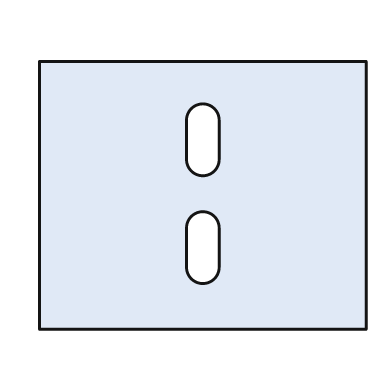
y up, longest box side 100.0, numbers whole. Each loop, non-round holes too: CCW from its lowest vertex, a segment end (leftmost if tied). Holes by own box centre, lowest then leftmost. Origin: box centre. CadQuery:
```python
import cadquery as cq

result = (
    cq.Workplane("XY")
    .moveTo(-50.0, -41.0)
    .lineTo(50.0, -41.0)
    .lineTo(50.0, 41.0)
    .lineTo(-50.0, 41.0)
    .close()
    .moveTo(-5.0, -22.0)
    .threePointArc((0.0, -27.0), (5.0, -22.0))
    .lineTo(5.0, -10.0)
    .threePointArc((0.0, -5.0), (-5.0, -10.0))
    .close()
    .moveTo(-5.0, 11.0)
    .threePointArc((0.0, 6.0), (5.0, 11.0))
    .lineTo(5.0, 23.0)
    .threePointArc((0.0, 28.0), (-5.0, 23.0))
    .close()
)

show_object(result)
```